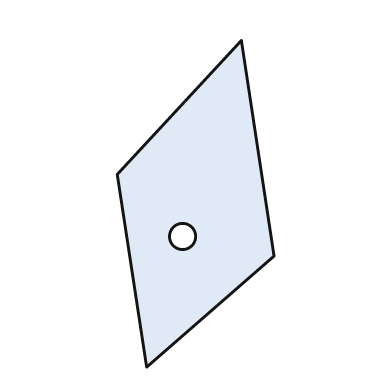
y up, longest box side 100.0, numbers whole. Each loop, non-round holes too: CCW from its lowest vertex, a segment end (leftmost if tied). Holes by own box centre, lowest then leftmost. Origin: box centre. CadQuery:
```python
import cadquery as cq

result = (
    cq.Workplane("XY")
    .moveTo(-15.0, -50.0)
    .lineTo(24.0, -16.0)
    .lineTo(14.0, 50.0)
    .lineTo(-24.0, 9.0)
    .close()
    .moveTo(-4.0, -10.0)
    .circle(4.0)
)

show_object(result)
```